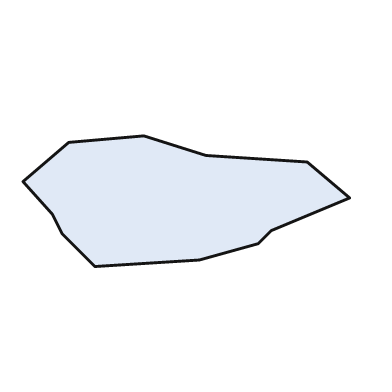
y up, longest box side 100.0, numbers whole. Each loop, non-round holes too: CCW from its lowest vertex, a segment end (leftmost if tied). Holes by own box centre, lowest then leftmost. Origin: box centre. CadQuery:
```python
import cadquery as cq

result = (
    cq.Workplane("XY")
    .moveTo(-28.0, -20.0)
    .lineTo(4.0, -18.0)
    .lineTo(22.0, -13.0)
    .lineTo(26.0, -9.0)
    .lineTo(50.0, 1.0)
    .lineTo(37.0, 12.0)
    .lineTo(6.0, 14.0)
    .lineTo(-13.0, 20.0)
    .lineTo(-36.0, 18.0)
    .lineTo(-50.0, 6.0)
    .lineTo(-41.0, -4.0)
    .lineTo(-38.0, -10.0)
    .close()
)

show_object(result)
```